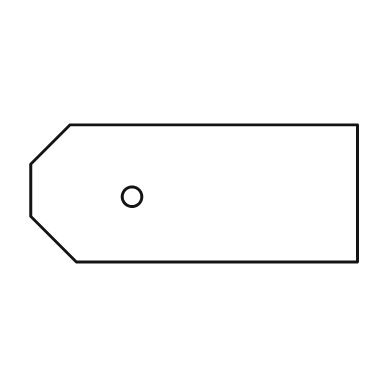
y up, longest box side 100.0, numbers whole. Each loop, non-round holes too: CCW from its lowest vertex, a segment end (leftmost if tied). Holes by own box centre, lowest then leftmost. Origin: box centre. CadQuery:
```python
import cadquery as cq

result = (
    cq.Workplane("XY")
    .moveTo(-36.0, -21.0)
    .lineTo(50.0, -21.0)
    .lineTo(50.0, 21.0)
    .lineTo(-38.0, 21.0)
    .lineTo(-50.0, 9.0)
    .lineTo(-50.0, -7.0)
    .close()
    .moveTo(-19.0, -1.0)
    .circle(3.0)
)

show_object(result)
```